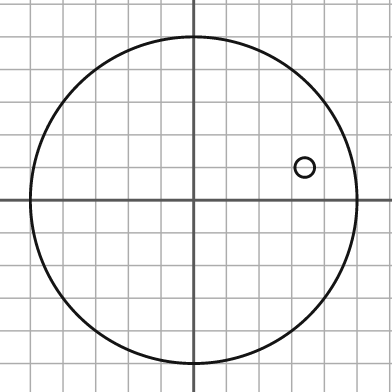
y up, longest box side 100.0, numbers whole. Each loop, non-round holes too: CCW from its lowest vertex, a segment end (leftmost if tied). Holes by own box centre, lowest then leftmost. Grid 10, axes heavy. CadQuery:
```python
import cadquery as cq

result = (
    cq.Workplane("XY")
    .moveTo(0.0, 0.0)
    .circle(50.0)
    .moveTo(34.0, 10.0)
    .circle(3.0)
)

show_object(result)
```